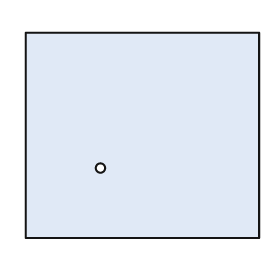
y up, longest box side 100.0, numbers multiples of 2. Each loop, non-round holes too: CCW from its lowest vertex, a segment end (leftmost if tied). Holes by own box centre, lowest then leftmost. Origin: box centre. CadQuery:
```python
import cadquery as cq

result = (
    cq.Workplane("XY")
    .moveTo(-50.0, -44.0)
    .lineTo(50.0, -44.0)
    .lineTo(50.0, 44.0)
    .lineTo(-50.0, 44.0)
    .close()
    .moveTo(-18.0, -14.0)
    .circle(2.0)
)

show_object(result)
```